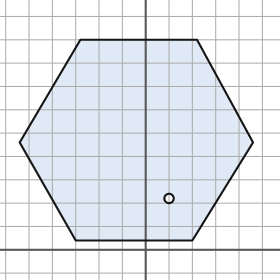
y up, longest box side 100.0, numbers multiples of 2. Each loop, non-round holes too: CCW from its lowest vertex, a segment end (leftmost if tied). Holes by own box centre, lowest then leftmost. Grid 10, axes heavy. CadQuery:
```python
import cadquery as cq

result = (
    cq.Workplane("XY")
    .moveTo(-30.0, 4.0)
    .lineTo(20.0, 4.0)
    .lineTo(46.0, 46.0)
    .lineTo(22.0, 90.0)
    .lineTo(-28.0, 90.0)
    .lineTo(-54.0, 46.0)
    .close()
    .moveTo(10.0, 22.0)
    .circle(2.0)
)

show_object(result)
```